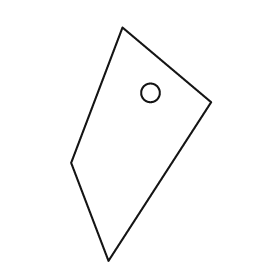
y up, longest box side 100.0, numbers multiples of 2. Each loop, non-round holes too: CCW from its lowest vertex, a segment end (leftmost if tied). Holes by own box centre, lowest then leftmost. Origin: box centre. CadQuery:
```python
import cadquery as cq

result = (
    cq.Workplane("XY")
    .moveTo(-14.0, -50.0)
    .lineTo(30.0, 18.0)
    .lineTo(-8.0, 50.0)
    .lineTo(-30.0, -8.0)
    .close()
    .moveTo(4.0, 22.0)
    .circle(4.0)
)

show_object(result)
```